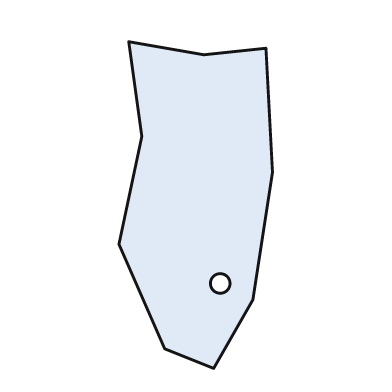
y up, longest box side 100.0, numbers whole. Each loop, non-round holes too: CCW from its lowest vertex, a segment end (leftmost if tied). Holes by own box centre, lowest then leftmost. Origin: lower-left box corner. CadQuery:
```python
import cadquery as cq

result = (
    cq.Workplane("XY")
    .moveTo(29.0, 0.0)
    .lineTo(41.0, 21.0)
    .lineTo(47.0, 60.0)
    .lineTo(45.0, 98.0)
    .lineTo(26.0, 96.0)
    .lineTo(3.0, 100.0)
    .lineTo(7.0, 71.0)
    .lineTo(0.0, 38.0)
    .lineTo(14.0, 6.0)
    .close()
    .moveTo(31.0, 26.0)
    .circle(3.0)
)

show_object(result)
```